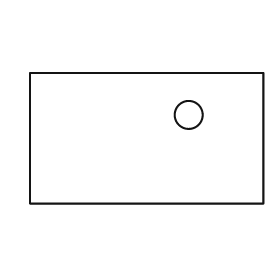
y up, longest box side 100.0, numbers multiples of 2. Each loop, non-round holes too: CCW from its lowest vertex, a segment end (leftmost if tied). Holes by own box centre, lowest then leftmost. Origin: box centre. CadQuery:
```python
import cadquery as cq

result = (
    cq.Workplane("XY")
    .moveTo(-50.0, -28.0)
    .lineTo(50.0, -28.0)
    .lineTo(50.0, 28.0)
    .lineTo(-50.0, 28.0)
    .close()
    .moveTo(18.0, 10.0)
    .circle(6.0)
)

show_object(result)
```